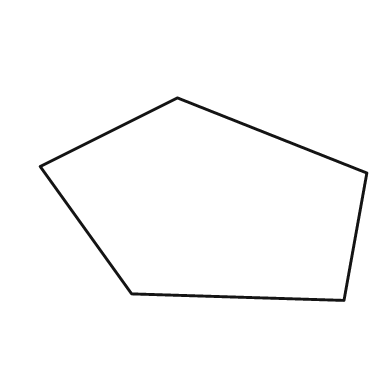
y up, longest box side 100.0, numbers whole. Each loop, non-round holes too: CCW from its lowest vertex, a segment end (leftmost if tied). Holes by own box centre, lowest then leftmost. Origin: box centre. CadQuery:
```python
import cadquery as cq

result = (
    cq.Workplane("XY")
    .moveTo(43.0, -31.0)
    .lineTo(50.0, 8.0)
    .lineTo(-8.0, 31.0)
    .lineTo(-50.0, 10.0)
    .lineTo(-22.0, -29.0)
    .close()
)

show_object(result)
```